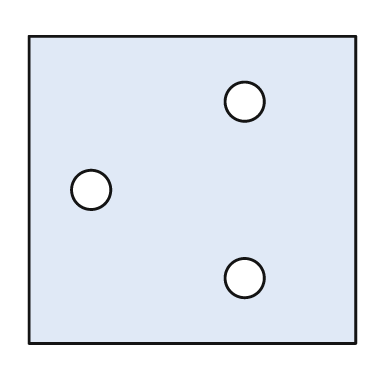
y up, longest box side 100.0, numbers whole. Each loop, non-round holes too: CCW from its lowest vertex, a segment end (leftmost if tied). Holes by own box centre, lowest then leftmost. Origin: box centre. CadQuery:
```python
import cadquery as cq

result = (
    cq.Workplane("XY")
    .moveTo(-50.0, -47.0)
    .lineTo(50.0, -47.0)
    .lineTo(50.0, 47.0)
    .lineTo(-50.0, 47.0)
    .close()
    .moveTo(16.0, -27.0)
    .circle(6.0)
    .moveTo(-31.0, 0.0)
    .circle(6.0)
    .moveTo(16.0, 27.0)
    .circle(6.0)
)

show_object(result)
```